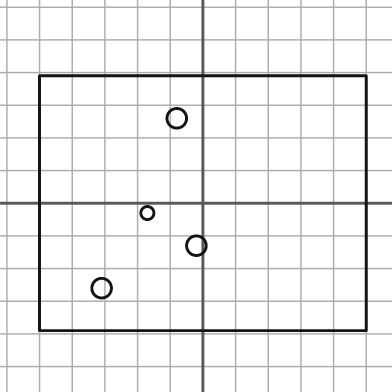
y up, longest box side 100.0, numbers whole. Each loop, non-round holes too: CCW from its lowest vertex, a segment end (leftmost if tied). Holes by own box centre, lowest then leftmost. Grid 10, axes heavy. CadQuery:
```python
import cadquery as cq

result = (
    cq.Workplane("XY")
    .moveTo(-50.0, -39.0)
    .lineTo(50.0, -39.0)
    .lineTo(50.0, 39.0)
    .lineTo(-50.0, 39.0)
    .close()
    .moveTo(-31.0, -26.0)
    .circle(3.0)
    .moveTo(-2.0, -13.0)
    .circle(3.0)
    .moveTo(-17.0, -3.0)
    .circle(2.0)
    .moveTo(-8.0, 26.0)
    .circle(3.0)
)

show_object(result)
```